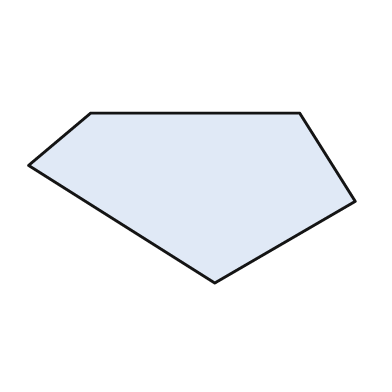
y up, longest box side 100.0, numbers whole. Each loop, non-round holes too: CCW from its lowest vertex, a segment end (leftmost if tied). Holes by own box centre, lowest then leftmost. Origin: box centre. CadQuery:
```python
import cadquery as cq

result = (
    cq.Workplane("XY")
    .moveTo(7.0, -26.0)
    .lineTo(50.0, -1.0)
    .lineTo(33.0, 26.0)
    .lineTo(-31.0, 26.0)
    .lineTo(-50.0, 10.0)
    .close()
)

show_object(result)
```